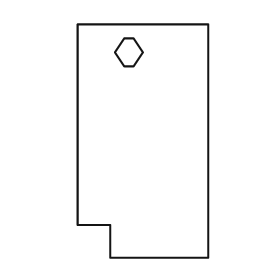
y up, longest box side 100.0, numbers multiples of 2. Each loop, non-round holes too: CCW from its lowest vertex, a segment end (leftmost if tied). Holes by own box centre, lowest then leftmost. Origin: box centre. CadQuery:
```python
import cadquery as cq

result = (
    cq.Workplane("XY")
    .moveTo(-14.0, -50.0)
    .lineTo(28.0, -50.0)
    .lineTo(28.0, 50.0)
    .lineTo(-28.0, 50.0)
    .lineTo(-28.0, -36.0)
    .lineTo(-14.0, -36.0)
    .close()
    .moveTo(-8.0, 32.0)
    .lineTo(-4.0, 32.0)
    .lineTo(0.0, 38.0)
    .lineTo(-4.0, 44.0)
    .lineTo(-8.0, 44.0)
    .lineTo(-12.0, 38.0)
    .close()
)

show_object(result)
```